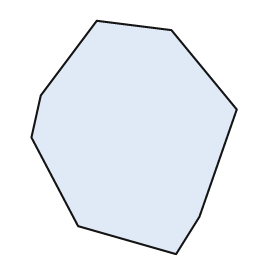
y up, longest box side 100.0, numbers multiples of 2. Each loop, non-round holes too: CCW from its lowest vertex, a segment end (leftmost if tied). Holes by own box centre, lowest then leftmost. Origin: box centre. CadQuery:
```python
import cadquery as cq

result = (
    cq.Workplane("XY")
    .moveTo(18.0, -50.0)
    .lineTo(28.0, -34.0)
    .lineTo(44.0, 12.0)
    .lineTo(16.0, 46.0)
    .lineTo(-16.0, 50.0)
    .lineTo(-40.0, 18.0)
    .lineTo(-44.0, 0.0)
    .lineTo(-24.0, -38.0)
    .close()
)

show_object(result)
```